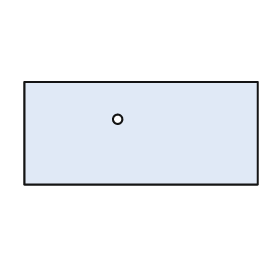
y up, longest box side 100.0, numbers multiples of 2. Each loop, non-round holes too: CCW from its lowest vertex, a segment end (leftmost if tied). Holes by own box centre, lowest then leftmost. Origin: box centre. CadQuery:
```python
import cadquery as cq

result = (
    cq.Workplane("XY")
    .moveTo(-50.0, -22.0)
    .lineTo(50.0, -22.0)
    .lineTo(50.0, 22.0)
    .lineTo(-50.0, 22.0)
    .close()
    .moveTo(-10.0, 6.0)
    .circle(2.0)
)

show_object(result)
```